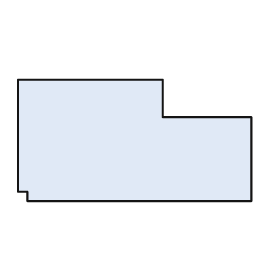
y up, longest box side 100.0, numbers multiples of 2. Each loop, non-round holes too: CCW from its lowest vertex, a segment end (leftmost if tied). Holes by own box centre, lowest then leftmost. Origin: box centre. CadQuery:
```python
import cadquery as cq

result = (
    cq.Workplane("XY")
    .moveTo(-46.0, -26.0)
    .lineTo(50.0, -26.0)
    .lineTo(50.0, 10.0)
    .lineTo(12.0, 10.0)
    .lineTo(12.0, 26.0)
    .lineTo(-50.0, 26.0)
    .lineTo(-50.0, -22.0)
    .lineTo(-46.0, -22.0)
    .close()
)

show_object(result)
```